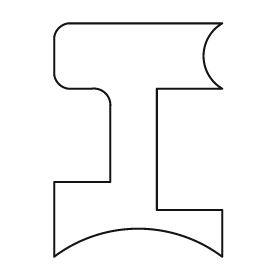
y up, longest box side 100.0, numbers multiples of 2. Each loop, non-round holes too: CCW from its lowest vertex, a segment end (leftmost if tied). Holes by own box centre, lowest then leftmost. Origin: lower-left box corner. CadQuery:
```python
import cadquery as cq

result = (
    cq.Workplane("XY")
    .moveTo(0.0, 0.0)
    .threePointArc((36.0, 12.0), (72.0, 0.0))
    .lineTo(72.0, 20.0)
    .lineTo(44.0, 20.0)
    .lineTo(44.0, 72.0)
    .lineTo(72.0, 72.0)
    .threePointArc((64.0, 86.0), (72.0, 100.0))
    .lineTo(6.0, 100.0)
    .threePointArc((2.0, 98.0), (0.0, 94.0))
    .lineTo(0.0, 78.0)
    .threePointArc((2.0, 74.0), (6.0, 72.0))
    .lineTo(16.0, 72.0)
    .threePointArc((22.0, 70.0), (24.0, 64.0))
    .lineTo(24.0, 32.0)
    .lineTo(0.0, 32.0)
    .close()
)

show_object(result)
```